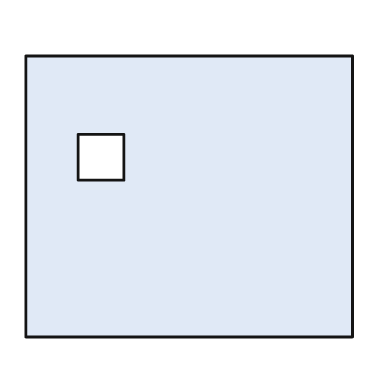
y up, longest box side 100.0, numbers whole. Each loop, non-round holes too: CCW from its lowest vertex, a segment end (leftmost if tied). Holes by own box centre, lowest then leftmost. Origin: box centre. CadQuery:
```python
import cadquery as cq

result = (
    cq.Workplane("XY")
    .moveTo(-50.0, -43.0)
    .lineTo(50.0, -43.0)
    .lineTo(50.0, 43.0)
    .lineTo(-50.0, 43.0)
    .close()
    .moveTo(-34.0, 5.0)
    .lineTo(-20.0, 5.0)
    .lineTo(-20.0, 19.0)
    .lineTo(-34.0, 19.0)
    .close()
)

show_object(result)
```